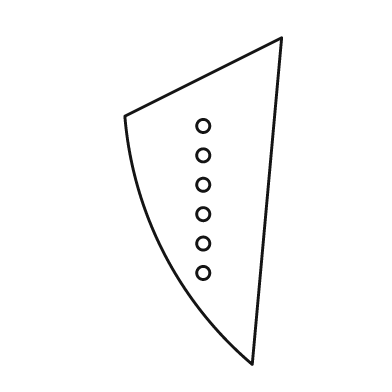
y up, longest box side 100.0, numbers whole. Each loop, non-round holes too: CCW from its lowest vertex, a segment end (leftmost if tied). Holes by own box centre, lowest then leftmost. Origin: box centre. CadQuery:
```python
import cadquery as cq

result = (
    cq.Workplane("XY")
    .moveTo(15.0, -50.0)
    .lineTo(24.0, 50.0)
    .lineTo(-24.0, 26.0)
    .threePointArc((-12.0, -16.0), (15.0, -50.0))
    .close()
    .moveTo(0.0, -22.0)
    .circle(2.0)
    .moveTo(0.0, -13.0)
    .circle(2.0)
    .moveTo(0.0, -4.0)
    .circle(2.0)
    .moveTo(0.0, 5.0)
    .circle(2.0)
    .moveTo(0.0, 14.0)
    .circle(2.0)
    .moveTo(0.0, 23.0)
    .circle(2.0)
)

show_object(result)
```